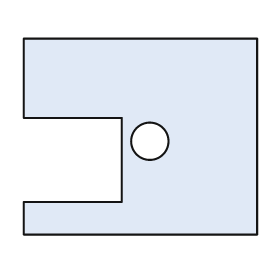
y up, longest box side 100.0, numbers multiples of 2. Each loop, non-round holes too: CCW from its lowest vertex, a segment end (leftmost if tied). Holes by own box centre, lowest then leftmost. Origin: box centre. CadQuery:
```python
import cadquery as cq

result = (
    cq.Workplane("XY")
    .moveTo(-50.0, -42.0)
    .lineTo(50.0, -42.0)
    .lineTo(50.0, 42.0)
    .lineTo(-50.0, 42.0)
    .lineTo(-50.0, 8.0)
    .lineTo(-8.0, 8.0)
    .lineTo(-8.0, -28.0)
    .lineTo(-50.0, -28.0)
    .close()
    .moveTo(4.0, -2.0)
    .circle(8.0)
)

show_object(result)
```